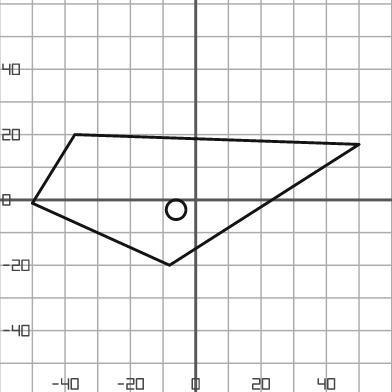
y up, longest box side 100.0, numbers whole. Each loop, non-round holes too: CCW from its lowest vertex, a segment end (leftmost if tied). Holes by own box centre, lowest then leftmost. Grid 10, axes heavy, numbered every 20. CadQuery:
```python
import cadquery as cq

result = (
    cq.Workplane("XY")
    .moveTo(-8.0, -20.0)
    .lineTo(50.0, 17.0)
    .lineTo(-37.0, 20.0)
    .lineTo(-50.0, -1.0)
    .close()
    .moveTo(-6.0, -3.0)
    .circle(3.0)
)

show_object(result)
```